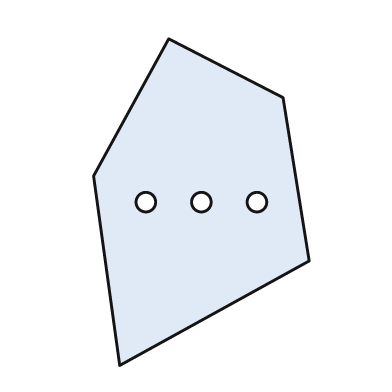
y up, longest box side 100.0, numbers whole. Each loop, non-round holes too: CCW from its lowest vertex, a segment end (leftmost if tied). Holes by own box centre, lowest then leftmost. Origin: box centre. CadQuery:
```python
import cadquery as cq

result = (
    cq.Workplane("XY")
    .moveTo(-25.0, -50.0)
    .lineTo(33.0, -18.0)
    .lineTo(25.0, 32.0)
    .lineTo(-10.0, 50.0)
    .lineTo(-33.0, 8.0)
    .close()
    .moveTo(-17.0, 0.0)
    .circle(3.0)
    .moveTo(0.0, 0.0)
    .circle(3.0)
    .moveTo(17.0, 0.0)
    .circle(3.0)
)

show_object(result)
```